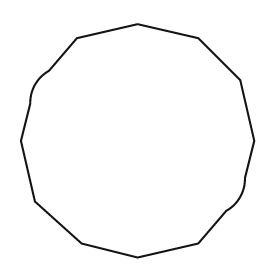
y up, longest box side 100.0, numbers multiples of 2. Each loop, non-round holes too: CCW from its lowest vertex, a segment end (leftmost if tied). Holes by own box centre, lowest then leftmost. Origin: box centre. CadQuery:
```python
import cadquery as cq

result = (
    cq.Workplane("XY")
    .moveTo(0.0, -50.0)
    .lineTo(26.0, -44.0)
    .lineTo(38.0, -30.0)
    .threePointArc((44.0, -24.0), (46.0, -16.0))
    .lineTo(50.0, 0.0)
    .lineTo(44.0, 26.0)
    .lineTo(26.0, 44.0)
    .lineTo(0.0, 50.0)
    .lineTo(-26.0, 44.0)
    .lineTo(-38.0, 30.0)
    .threePointArc((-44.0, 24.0), (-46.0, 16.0))
    .lineTo(-50.0, 0.0)
    .lineTo(-44.0, -26.0)
    .lineTo(-24.0, -44.0)
    .close()
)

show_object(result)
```